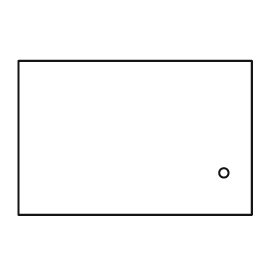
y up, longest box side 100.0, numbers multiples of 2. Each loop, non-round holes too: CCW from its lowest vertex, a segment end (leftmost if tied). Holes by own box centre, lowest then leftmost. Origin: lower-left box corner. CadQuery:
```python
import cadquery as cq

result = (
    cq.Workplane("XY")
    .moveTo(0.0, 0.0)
    .lineTo(100.0, 0.0)
    .lineTo(100.0, 66.0)
    .lineTo(0.0, 66.0)
    .close()
    .moveTo(88.0, 18.0)
    .circle(2.0)
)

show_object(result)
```